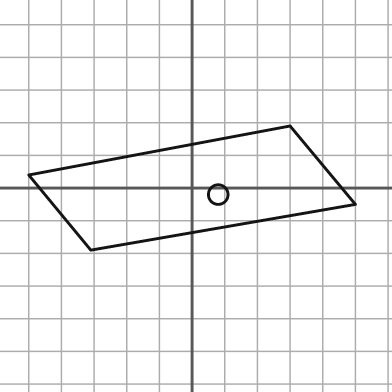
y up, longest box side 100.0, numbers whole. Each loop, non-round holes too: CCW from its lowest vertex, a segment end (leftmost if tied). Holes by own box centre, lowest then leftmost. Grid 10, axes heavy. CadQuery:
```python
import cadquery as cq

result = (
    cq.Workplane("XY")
    .moveTo(-31.0, -19.0)
    .lineTo(50.0, -5.0)
    .lineTo(30.0, 19.0)
    .lineTo(-50.0, 4.0)
    .close()
    .moveTo(8.0, -2.0)
    .circle(3.0)
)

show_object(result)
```